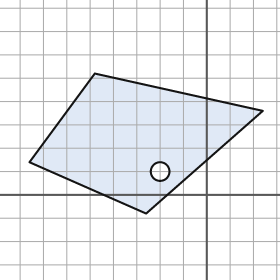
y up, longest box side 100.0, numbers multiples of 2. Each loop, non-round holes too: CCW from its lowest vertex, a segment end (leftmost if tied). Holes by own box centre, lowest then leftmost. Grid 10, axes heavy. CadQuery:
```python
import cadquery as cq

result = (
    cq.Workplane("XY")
    .moveTo(-26.0, -8.0)
    .lineTo(24.0, 36.0)
    .lineTo(-48.0, 52.0)
    .lineTo(-76.0, 14.0)
    .close()
    .moveTo(-20.0, 10.0)
    .circle(4.0)
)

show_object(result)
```